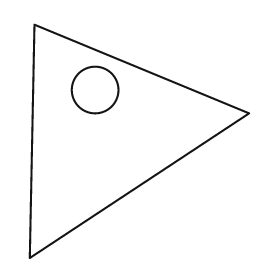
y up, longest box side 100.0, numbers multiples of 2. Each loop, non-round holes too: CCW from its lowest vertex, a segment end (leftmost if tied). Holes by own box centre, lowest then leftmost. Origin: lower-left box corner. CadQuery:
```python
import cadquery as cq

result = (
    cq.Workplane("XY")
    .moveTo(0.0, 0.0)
    .lineTo(94.0, 62.0)
    .lineTo(2.0, 100.0)
    .close()
    .moveTo(28.0, 72.0)
    .circle(10.0)
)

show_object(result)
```